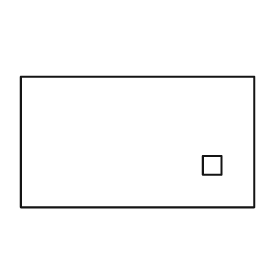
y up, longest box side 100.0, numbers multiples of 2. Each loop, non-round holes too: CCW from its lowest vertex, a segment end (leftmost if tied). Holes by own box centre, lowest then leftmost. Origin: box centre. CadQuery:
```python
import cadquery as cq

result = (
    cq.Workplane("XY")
    .moveTo(-50.0, -28.0)
    .lineTo(50.0, -28.0)
    .lineTo(50.0, 28.0)
    .lineTo(-50.0, 28.0)
    .close()
    .moveTo(28.0, -14.0)
    .lineTo(36.0, -14.0)
    .lineTo(36.0, -6.0)
    .lineTo(28.0, -6.0)
    .close()
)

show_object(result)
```